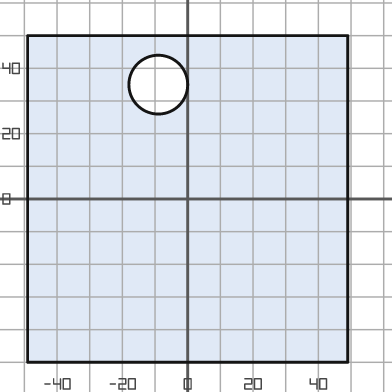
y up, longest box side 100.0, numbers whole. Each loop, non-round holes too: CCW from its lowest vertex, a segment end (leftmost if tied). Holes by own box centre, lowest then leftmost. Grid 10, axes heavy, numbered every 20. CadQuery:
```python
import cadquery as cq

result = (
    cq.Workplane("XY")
    .moveTo(-49.0, -50.0)
    .lineTo(49.0, -50.0)
    .lineTo(49.0, 50.0)
    .lineTo(-49.0, 50.0)
    .close()
    .moveTo(-9.0, 35.0)
    .circle(9.0)
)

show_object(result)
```